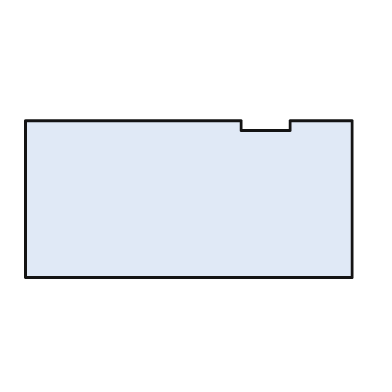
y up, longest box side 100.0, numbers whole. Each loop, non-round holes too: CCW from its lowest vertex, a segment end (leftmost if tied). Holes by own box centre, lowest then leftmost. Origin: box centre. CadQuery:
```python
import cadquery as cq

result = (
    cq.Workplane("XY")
    .moveTo(-50.0, -24.0)
    .lineTo(50.0, -24.0)
    .lineTo(50.0, 24.0)
    .lineTo(31.0, 24.0)
    .lineTo(31.0, 21.0)
    .lineTo(16.0, 21.0)
    .lineTo(16.0, 24.0)
    .lineTo(-50.0, 24.0)
    .close()
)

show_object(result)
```